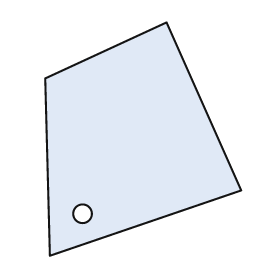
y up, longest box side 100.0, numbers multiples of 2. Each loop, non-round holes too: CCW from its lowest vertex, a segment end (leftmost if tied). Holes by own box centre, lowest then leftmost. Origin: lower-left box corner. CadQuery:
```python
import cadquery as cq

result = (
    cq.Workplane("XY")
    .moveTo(2.0, 0.0)
    .lineTo(84.0, 28.0)
    .lineTo(52.0, 100.0)
    .lineTo(0.0, 76.0)
    .close()
    .moveTo(16.0, 18.0)
    .circle(4.0)
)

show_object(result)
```